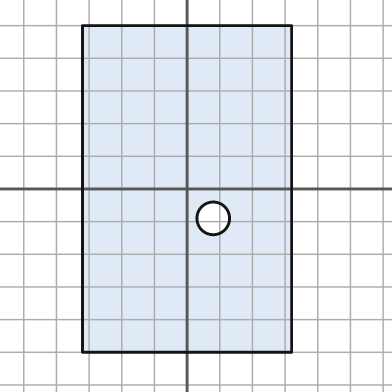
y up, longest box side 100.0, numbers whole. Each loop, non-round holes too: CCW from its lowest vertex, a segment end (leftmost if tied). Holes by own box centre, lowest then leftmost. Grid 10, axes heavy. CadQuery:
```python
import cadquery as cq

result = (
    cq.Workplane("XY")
    .moveTo(-32.0, -50.0)
    .lineTo(32.0, -50.0)
    .lineTo(32.0, 50.0)
    .lineTo(-32.0, 50.0)
    .close()
    .moveTo(8.0, -9.0)
    .circle(5.0)
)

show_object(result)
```